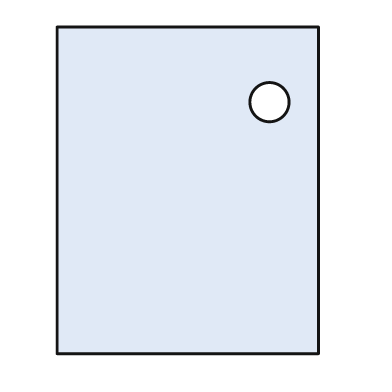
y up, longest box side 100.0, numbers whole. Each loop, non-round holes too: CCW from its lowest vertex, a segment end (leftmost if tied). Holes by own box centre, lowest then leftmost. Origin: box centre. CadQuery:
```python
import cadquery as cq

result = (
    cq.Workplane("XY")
    .moveTo(-40.0, -50.0)
    .lineTo(40.0, -50.0)
    .lineTo(40.0, 50.0)
    .lineTo(-40.0, 50.0)
    .close()
    .moveTo(25.0, 27.0)
    .circle(6.0)
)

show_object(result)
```